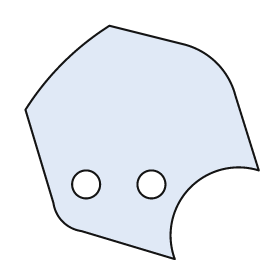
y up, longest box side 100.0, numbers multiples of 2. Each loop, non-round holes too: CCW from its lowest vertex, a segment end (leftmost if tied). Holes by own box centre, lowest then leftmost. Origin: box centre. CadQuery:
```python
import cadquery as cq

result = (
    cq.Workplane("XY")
    .moveTo(14.0, -50.0)
    .threePointArc((20.0, -20.0), (50.0, -12.0))
    .lineTo(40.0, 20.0)
    .threePointArc((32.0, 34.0), (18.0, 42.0))
    .lineTo(-14.0, 50.0)
    .threePointArc((-34.0, 34.0), (-50.0, 14.0))
    .lineTo(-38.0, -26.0)
    .threePointArc((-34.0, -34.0), (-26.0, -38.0))
    .close()
    .moveTo(-24.0, -18.0)
    .circle(6.0)
    .moveTo(4.0, -18.0)
    .circle(6.0)
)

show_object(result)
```